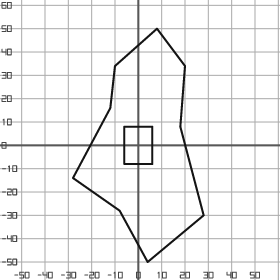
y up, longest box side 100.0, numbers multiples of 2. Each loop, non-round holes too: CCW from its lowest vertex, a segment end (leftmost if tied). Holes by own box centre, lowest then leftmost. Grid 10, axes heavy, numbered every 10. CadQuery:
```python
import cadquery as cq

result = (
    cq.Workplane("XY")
    .moveTo(4.0, -50.0)
    .lineTo(28.0, -30.0)
    .lineTo(18.0, 8.0)
    .lineTo(20.0, 34.0)
    .lineTo(8.0, 50.0)
    .lineTo(-10.0, 34.0)
    .lineTo(-12.0, 16.0)
    .lineTo(-28.0, -14.0)
    .lineTo(-8.0, -28.0)
    .close()
    .moveTo(-6.0, -8.0)
    .lineTo(6.0, -8.0)
    .lineTo(6.0, 8.0)
    .lineTo(-6.0, 8.0)
    .close()
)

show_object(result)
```